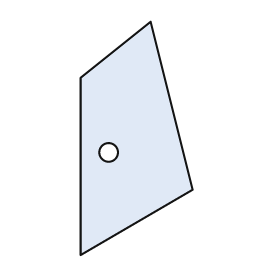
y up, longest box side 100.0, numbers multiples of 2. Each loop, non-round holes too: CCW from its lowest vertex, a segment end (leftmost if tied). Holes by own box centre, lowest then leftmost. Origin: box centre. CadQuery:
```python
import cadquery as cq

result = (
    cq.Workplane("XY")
    .moveTo(-24.0, -50.0)
    .lineTo(24.0, -22.0)
    .lineTo(6.0, 50.0)
    .lineTo(-24.0, 26.0)
    .close()
    .moveTo(-12.0, -6.0)
    .circle(4.0)
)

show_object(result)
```